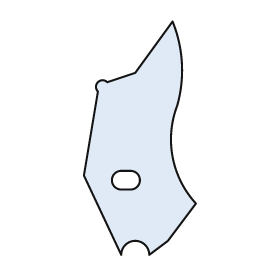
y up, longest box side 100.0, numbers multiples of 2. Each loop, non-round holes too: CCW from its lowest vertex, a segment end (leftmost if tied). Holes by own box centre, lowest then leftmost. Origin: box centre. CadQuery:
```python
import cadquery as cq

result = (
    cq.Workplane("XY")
    .moveTo(-8.0, -50.0)
    .threePointArc((-2.0, -44.0), (4.0, -50.0))
    .lineTo(12.0, -44.0)
    .lineTo(24.0, -28.0)
    .threePointArc((14.0, -8.0), (16.0, 14.0))
    .threePointArc((18.0, 32.0), (14.0, 50.0))
    .lineTo(-2.0, 28.0)
    .lineTo(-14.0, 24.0)
    .threePointArc((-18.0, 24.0), (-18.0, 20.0))
    .lineTo(-24.0, -16.0)
    .close()
    .moveTo(-8.0, -22.0)
    .lineTo(-4.0, -22.0)
    .threePointArc((0.0, -18.0), (-4.0, -14.0))
    .lineTo(-8.0, -14.0)
    .threePointArc((-12.0, -18.0), (-8.0, -22.0))
    .close()
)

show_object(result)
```